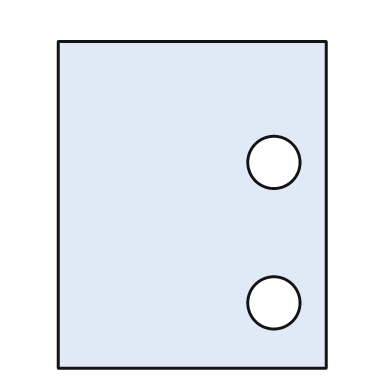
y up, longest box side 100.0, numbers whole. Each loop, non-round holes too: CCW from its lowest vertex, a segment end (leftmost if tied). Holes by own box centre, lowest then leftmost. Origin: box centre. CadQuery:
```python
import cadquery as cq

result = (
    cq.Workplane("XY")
    .moveTo(-41.0, -50.0)
    .lineTo(41.0, -50.0)
    .lineTo(41.0, 50.0)
    .lineTo(-41.0, 50.0)
    .close()
    .moveTo(25.0, -30.0)
    .circle(8.0)
    .moveTo(25.0, 13.0)
    .circle(8.0)
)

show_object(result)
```